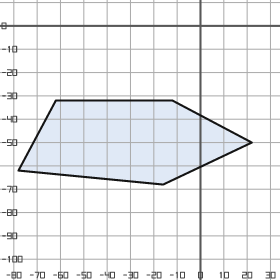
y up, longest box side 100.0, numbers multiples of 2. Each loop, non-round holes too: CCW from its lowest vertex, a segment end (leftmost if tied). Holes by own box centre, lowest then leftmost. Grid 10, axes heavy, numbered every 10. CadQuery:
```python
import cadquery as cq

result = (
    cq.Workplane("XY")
    .moveTo(-16.0, -68.0)
    .lineTo(22.0, -50.0)
    .lineTo(-12.0, -32.0)
    .lineTo(-62.0, -32.0)
    .lineTo(-78.0, -62.0)
    .close()
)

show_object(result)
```